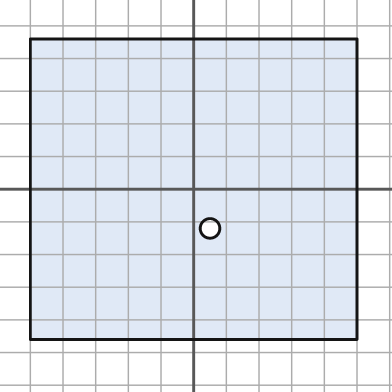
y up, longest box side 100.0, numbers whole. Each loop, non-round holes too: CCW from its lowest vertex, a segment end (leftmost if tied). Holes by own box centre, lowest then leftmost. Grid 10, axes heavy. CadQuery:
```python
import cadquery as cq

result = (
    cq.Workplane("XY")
    .moveTo(-50.0, -46.0)
    .lineTo(50.0, -46.0)
    .lineTo(50.0, 46.0)
    .lineTo(-50.0, 46.0)
    .close()
    .moveTo(5.0, -12.0)
    .circle(3.0)
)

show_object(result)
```